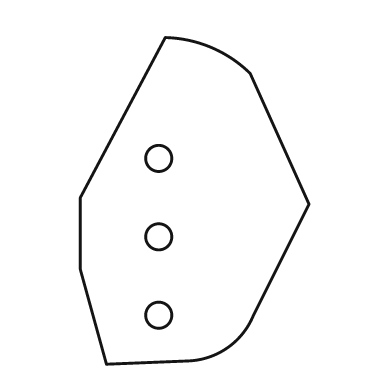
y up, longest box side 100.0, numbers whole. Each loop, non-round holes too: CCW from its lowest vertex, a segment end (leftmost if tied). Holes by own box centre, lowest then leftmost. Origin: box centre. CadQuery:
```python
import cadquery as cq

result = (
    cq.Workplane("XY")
    .moveTo(-27.0, -50.0)
    .lineTo(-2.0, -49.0)
    .threePointArc((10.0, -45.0), (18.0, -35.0))
    .lineTo(35.0, -1.0)
    .lineTo(17.0, 39.0)
    .threePointArc((5.0, 47.0), (-9.0, 50.0))
    .lineTo(-35.0, 1.0)
    .lineTo(-35.0, -21.0)
    .close()
    .moveTo(-11.0, -35.0)
    .circle(4.0)
    .moveTo(-11.0, -11.0)
    .circle(4.0)
    .moveTo(-11.0, 13.0)
    .circle(4.0)
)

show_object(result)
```